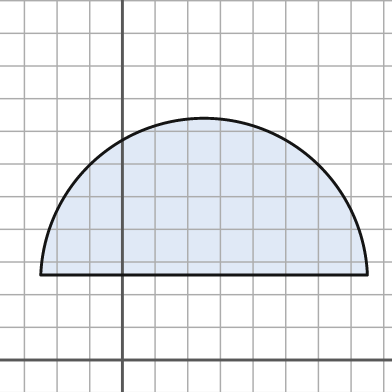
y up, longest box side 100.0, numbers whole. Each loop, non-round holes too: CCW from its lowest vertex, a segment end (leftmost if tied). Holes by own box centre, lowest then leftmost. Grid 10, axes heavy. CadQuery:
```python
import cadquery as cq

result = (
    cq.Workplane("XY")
    .moveTo(-25.0, 26.0)
    .lineTo(75.0, 26.0)
    .threePointArc((25.0, 74.0), (-25.0, 26.0))
    .close()
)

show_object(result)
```